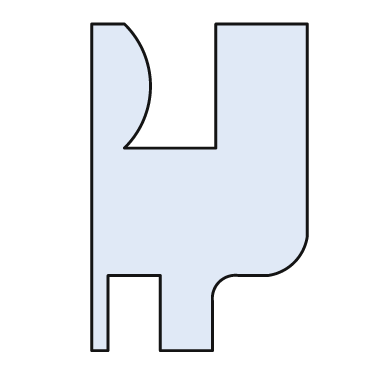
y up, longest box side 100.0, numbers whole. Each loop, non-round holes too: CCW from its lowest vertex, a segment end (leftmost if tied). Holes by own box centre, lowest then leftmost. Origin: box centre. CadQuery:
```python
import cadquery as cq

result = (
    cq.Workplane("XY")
    .moveTo(-33.0, -50.0)
    .lineTo(-28.0, -50.0)
    .lineTo(-28.0, -27.0)
    .lineTo(-12.0, -27.0)
    .lineTo(-12.0, -50.0)
    .lineTo(4.0, -50.0)
    .lineTo(4.0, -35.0)
    .threePointArc((6.0, -29.0), (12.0, -27.0))
    .lineTo(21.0, -27.0)
    .threePointArc((29.0, -23.0), (33.0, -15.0))
    .lineTo(33.0, 50.0)
    .lineTo(5.0, 50.0)
    .lineTo(5.0, 12.0)
    .lineTo(-23.0, 12.0)
    .threePointArc((-15.0, 31.0), (-23.0, 50.0))
    .lineTo(-33.0, 50.0)
    .close()
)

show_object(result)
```